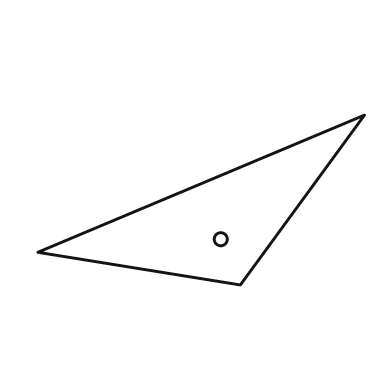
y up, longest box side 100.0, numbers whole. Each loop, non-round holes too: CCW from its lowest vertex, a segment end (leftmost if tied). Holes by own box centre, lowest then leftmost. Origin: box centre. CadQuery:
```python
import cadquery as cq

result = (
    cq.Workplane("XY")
    .moveTo(12.0, -26.0)
    .lineTo(50.0, 26.0)
    .lineTo(-50.0, -16.0)
    .close()
    .moveTo(6.0, -12.0)
    .circle(2.0)
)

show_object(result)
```